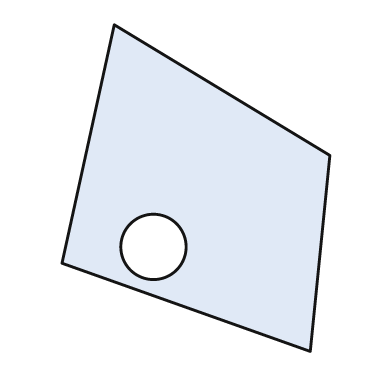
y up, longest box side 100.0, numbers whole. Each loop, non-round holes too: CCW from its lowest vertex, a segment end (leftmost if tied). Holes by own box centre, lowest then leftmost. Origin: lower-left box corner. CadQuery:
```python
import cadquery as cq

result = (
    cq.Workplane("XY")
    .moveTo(76.0, 0.0)
    .lineTo(82.0, 60.0)
    .lineTo(16.0, 100.0)
    .lineTo(0.0, 27.0)
    .close()
    .moveTo(28.0, 32.0)
    .circle(10.0)
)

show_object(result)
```